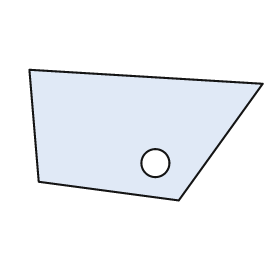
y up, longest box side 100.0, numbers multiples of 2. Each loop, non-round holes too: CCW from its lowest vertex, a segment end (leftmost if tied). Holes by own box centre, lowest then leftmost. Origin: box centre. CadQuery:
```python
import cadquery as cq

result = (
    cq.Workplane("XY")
    .moveTo(14.0, -28.0)
    .lineTo(50.0, 22.0)
    .lineTo(-50.0, 28.0)
    .lineTo(-46.0, -20.0)
    .close()
    .moveTo(4.0, -12.0)
    .circle(6.0)
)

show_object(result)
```